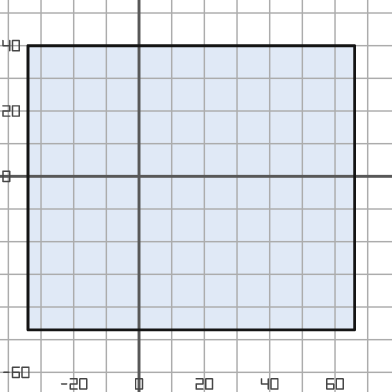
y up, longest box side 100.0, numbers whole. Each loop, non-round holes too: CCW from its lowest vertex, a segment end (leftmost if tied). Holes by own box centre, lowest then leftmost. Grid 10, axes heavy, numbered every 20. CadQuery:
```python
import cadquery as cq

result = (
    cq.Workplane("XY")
    .moveTo(-34.0, -47.0)
    .lineTo(66.0, -47.0)
    .lineTo(66.0, 40.0)
    .lineTo(-34.0, 40.0)
    .close()
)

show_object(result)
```